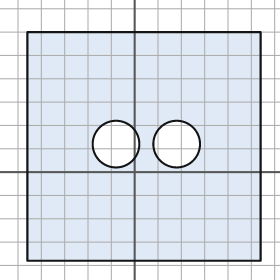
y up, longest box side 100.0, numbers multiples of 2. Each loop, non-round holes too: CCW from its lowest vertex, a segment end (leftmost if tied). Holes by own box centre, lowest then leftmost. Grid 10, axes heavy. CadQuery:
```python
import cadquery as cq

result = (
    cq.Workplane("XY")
    .moveTo(-46.0, -38.0)
    .lineTo(54.0, -38.0)
    .lineTo(54.0, 60.0)
    .lineTo(-46.0, 60.0)
    .close()
    .moveTo(-8.0, 12.0)
    .circle(10.0)
    .moveTo(18.0, 12.0)
    .circle(10.0)
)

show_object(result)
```